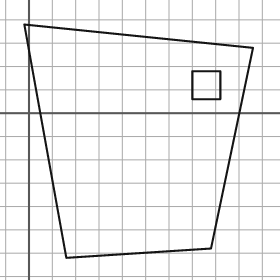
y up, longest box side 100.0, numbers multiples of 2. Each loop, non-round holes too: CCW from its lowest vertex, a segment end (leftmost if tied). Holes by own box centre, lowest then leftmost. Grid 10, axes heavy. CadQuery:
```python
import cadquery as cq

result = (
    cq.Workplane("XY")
    .moveTo(16.0, -62.0)
    .lineTo(78.0, -58.0)
    .lineTo(96.0, 28.0)
    .lineTo(-2.0, 38.0)
    .close()
    .moveTo(70.0, 6.0)
    .lineTo(82.0, 6.0)
    .lineTo(82.0, 18.0)
    .lineTo(70.0, 18.0)
    .close()
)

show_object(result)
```